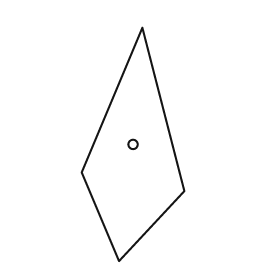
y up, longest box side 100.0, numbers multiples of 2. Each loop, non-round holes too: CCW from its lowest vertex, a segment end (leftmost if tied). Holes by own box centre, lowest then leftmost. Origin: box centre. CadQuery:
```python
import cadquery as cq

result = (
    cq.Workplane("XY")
    .moveTo(-6.0, -50.0)
    .lineTo(22.0, -20.0)
    .lineTo(4.0, 50.0)
    .lineTo(-22.0, -12.0)
    .close()
    .moveTo(0.0, 0.0)
    .circle(2.0)
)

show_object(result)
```